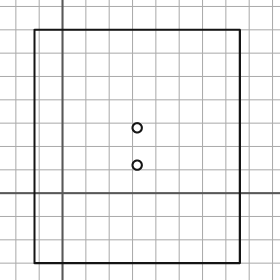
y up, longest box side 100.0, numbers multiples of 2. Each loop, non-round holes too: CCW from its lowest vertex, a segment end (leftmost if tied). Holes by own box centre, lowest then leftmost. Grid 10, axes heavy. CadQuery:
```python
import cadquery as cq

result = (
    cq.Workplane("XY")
    .moveTo(-12.0, -30.0)
    .lineTo(76.0, -30.0)
    .lineTo(76.0, 70.0)
    .lineTo(-12.0, 70.0)
    .close()
    .moveTo(32.0, 12.0)
    .circle(2.0)
    .moveTo(32.0, 28.0)
    .circle(2.0)
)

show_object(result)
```